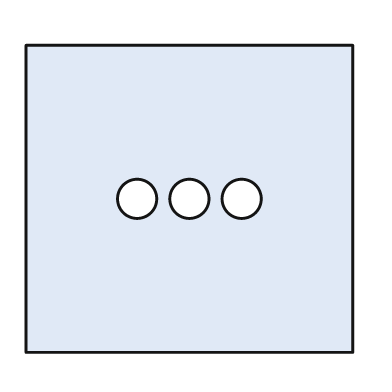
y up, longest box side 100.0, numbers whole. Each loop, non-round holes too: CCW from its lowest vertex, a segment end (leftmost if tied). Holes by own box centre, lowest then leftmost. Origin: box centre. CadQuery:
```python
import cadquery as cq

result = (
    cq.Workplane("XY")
    .moveTo(-50.0, -47.0)
    .lineTo(50.0, -47.0)
    .lineTo(50.0, 47.0)
    .lineTo(-50.0, 47.0)
    .close()
    .moveTo(-16.0, 0.0)
    .circle(6.0)
    .moveTo(0.0, 0.0)
    .circle(6.0)
    .moveTo(16.0, 0.0)
    .circle(6.0)
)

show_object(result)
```